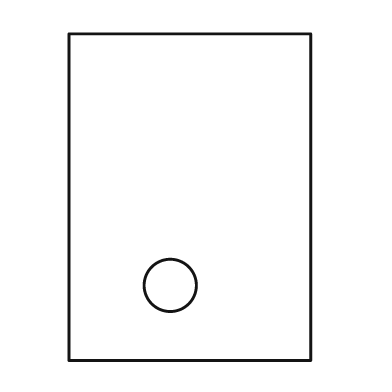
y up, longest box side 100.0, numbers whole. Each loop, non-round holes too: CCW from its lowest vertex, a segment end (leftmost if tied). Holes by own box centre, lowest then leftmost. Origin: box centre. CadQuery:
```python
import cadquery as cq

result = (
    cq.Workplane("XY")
    .moveTo(-37.0, -50.0)
    .lineTo(37.0, -50.0)
    .lineTo(37.0, 50.0)
    .lineTo(-37.0, 50.0)
    .close()
    .moveTo(-6.0, -27.0)
    .circle(8.0)
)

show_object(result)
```